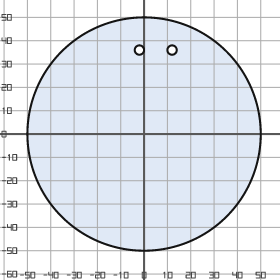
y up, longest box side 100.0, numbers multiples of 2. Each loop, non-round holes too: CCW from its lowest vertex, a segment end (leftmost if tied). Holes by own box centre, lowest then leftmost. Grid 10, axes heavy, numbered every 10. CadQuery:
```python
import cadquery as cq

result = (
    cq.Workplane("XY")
    .moveTo(0.0, 0.0)
    .circle(50.0)
    .moveTo(-2.0, 36.0)
    .circle(2.0)
    .moveTo(12.0, 36.0)
    .circle(2.0)
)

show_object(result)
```